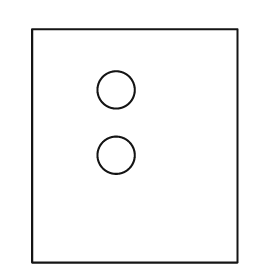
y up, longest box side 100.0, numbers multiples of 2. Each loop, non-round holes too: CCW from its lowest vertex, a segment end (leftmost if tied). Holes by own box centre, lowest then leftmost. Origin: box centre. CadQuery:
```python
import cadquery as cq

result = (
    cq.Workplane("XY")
    .moveTo(-44.0, -50.0)
    .lineTo(44.0, -50.0)
    .lineTo(44.0, 50.0)
    .lineTo(-44.0, 50.0)
    .close()
    .moveTo(-8.0, -4.0)
    .circle(8.0)
    .moveTo(-8.0, 24.0)
    .circle(8.0)
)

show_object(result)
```